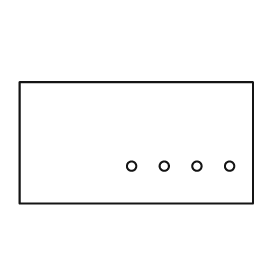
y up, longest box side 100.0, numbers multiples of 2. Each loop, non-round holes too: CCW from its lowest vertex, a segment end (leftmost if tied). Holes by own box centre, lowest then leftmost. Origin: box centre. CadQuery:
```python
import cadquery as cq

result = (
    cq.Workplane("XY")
    .moveTo(-50.0, -26.0)
    .lineTo(50.0, -26.0)
    .lineTo(50.0, 26.0)
    .lineTo(-50.0, 26.0)
    .close()
    .moveTo(-2.0, -10.0)
    .circle(2.0)
    .moveTo(12.0, -10.0)
    .circle(2.0)
    .moveTo(26.0, -10.0)
    .circle(2.0)
    .moveTo(40.0, -10.0)
    .circle(2.0)
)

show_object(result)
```